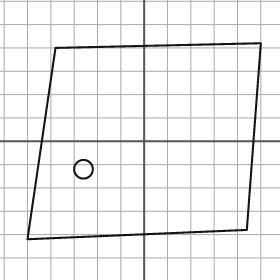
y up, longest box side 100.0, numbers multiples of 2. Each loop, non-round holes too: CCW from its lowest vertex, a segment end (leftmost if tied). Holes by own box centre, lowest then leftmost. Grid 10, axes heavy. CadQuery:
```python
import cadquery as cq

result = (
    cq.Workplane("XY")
    .moveTo(-50.0, -42.0)
    .lineTo(44.0, -38.0)
    .lineTo(50.0, 42.0)
    .lineTo(-38.0, 40.0)
    .close()
    .moveTo(-26.0, -12.0)
    .circle(4.0)
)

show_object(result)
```